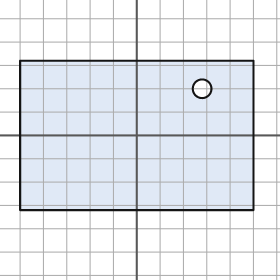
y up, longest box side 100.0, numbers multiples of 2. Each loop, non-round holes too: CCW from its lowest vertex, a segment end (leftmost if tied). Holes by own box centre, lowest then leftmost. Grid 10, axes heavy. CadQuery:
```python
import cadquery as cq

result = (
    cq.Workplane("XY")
    .moveTo(-50.0, -32.0)
    .lineTo(50.0, -32.0)
    .lineTo(50.0, 32.0)
    .lineTo(-50.0, 32.0)
    .close()
    .moveTo(28.0, 20.0)
    .circle(4.0)
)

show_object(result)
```